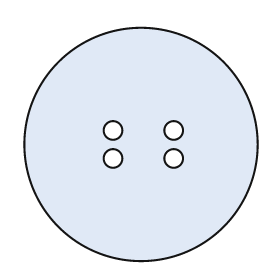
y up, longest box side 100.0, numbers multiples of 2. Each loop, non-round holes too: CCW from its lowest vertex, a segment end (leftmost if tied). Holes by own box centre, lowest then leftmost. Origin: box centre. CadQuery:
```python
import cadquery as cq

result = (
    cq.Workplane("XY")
    .moveTo(0.0, 0.0)
    .circle(50.0)
    .moveTo(-12.0, -6.0)
    .circle(4.0)
    .moveTo(14.0, -6.0)
    .circle(4.0)
    .moveTo(-12.0, 6.0)
    .circle(4.0)
    .moveTo(14.0, 6.0)
    .circle(4.0)
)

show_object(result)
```